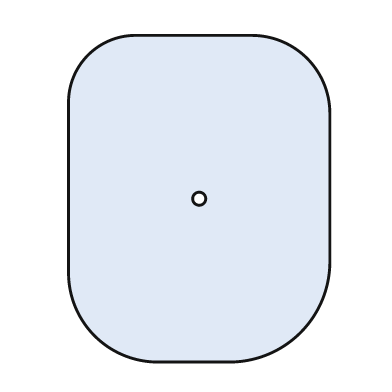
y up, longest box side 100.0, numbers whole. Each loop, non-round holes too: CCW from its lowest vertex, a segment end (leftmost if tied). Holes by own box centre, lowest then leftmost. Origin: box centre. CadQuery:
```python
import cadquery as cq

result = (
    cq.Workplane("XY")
    .moveTo(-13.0, -50.0)
    .lineTo(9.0, -50.0)
    .threePointArc((31.0, -41.0), (40.0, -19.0))
    .lineTo(40.0, 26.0)
    .threePointArc((33.0, 43.0), (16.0, 50.0))
    .lineTo(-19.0, 50.0)
    .threePointArc((-34.0, 44.0), (-40.0, 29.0))
    .lineTo(-40.0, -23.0)
    .threePointArc((-32.0, -42.0), (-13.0, -50.0))
    .close()
    .moveTo(0.0, 0.0)
    .circle(2.0)
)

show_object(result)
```